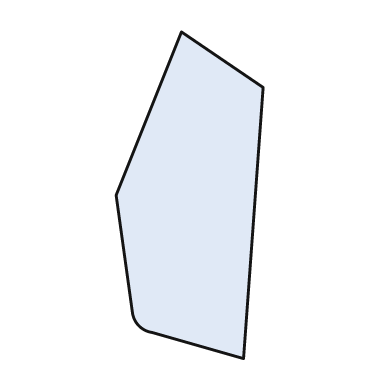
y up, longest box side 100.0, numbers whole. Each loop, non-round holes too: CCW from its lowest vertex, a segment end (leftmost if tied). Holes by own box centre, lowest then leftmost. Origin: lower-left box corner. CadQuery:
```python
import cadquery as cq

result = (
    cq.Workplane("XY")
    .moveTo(39.0, 0.0)
    .lineTo(45.0, 83.0)
    .lineTo(20.0, 100.0)
    .lineTo(0.0, 50.0)
    .lineTo(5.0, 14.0)
    .threePointArc((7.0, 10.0), (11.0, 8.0))
    .close()
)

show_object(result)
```